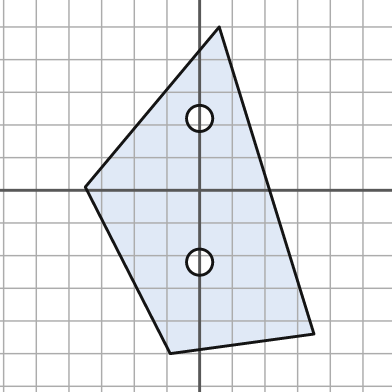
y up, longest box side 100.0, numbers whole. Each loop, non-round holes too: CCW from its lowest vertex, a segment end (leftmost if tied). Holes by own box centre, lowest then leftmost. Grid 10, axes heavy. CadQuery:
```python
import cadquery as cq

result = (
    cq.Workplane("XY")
    .moveTo(-9.0, -50.0)
    .lineTo(35.0, -44.0)
    .lineTo(6.0, 50.0)
    .lineTo(-35.0, 1.0)
    .close()
    .moveTo(0.0, -22.0)
    .circle(4.0)
    .moveTo(0.0, 22.0)
    .circle(4.0)
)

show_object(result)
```